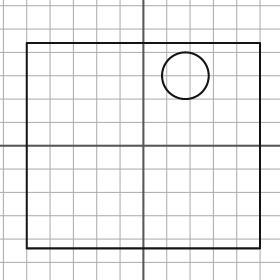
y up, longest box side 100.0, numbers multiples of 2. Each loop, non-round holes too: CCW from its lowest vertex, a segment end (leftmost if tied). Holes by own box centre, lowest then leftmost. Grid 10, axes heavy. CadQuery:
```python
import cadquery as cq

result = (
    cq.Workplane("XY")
    .moveTo(-50.0, -44.0)
    .lineTo(50.0, -44.0)
    .lineTo(50.0, 44.0)
    .lineTo(-50.0, 44.0)
    .close()
    .moveTo(18.0, 30.0)
    .circle(10.0)
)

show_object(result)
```